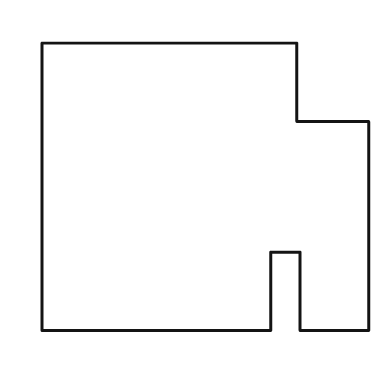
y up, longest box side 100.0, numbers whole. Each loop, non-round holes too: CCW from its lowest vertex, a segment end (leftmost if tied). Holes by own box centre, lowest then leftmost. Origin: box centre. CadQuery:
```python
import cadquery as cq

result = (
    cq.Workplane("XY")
    .moveTo(-50.0, -44.0)
    .lineTo(20.0, -44.0)
    .lineTo(20.0, -20.0)
    .lineTo(29.0, -20.0)
    .lineTo(29.0, -44.0)
    .lineTo(50.0, -44.0)
    .lineTo(50.0, 20.0)
    .lineTo(28.0, 20.0)
    .lineTo(28.0, 44.0)
    .lineTo(-50.0, 44.0)
    .close()
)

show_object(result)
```